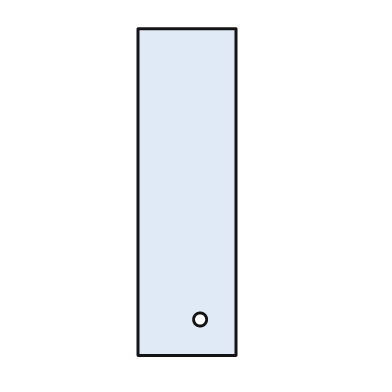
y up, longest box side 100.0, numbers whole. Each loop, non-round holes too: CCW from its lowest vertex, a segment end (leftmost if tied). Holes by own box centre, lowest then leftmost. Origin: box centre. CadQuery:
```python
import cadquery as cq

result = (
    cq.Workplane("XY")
    .moveTo(-15.0, -50.0)
    .lineTo(15.0, -50.0)
    .lineTo(15.0, 50.0)
    .lineTo(-15.0, 50.0)
    .close()
    .moveTo(4.0, -39.0)
    .circle(2.0)
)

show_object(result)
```